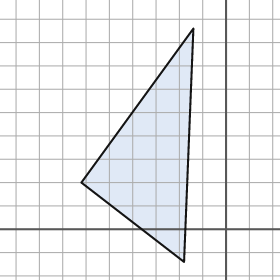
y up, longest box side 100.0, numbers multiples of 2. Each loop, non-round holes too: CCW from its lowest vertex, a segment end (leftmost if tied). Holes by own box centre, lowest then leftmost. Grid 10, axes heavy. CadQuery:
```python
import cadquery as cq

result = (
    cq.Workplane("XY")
    .moveTo(-18.0, -14.0)
    .lineTo(-14.0, 86.0)
    .lineTo(-62.0, 20.0)
    .close()
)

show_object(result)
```